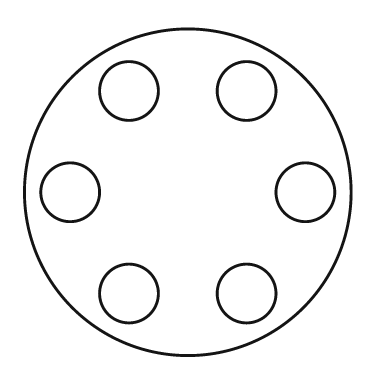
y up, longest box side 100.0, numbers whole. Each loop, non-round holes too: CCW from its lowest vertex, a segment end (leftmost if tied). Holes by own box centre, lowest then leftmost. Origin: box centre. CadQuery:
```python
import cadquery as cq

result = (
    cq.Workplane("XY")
    .moveTo(0.0, 0.0)
    .circle(50.0)
    .moveTo(-18.0, -31.0)
    .circle(9.0)
    .moveTo(18.0, -31.0)
    .circle(9.0)
    .moveTo(-36.0, 0.0)
    .circle(9.0)
    .moveTo(36.0, 0.0)
    .circle(9.0)
    .moveTo(-18.0, 31.0)
    .circle(9.0)
    .moveTo(18.0, 31.0)
    .circle(9.0)
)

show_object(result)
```